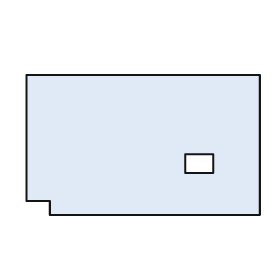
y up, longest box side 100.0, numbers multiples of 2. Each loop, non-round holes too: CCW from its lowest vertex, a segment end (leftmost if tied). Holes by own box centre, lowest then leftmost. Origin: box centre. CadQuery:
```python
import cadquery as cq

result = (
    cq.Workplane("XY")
    .moveTo(-40.0, -30.0)
    .lineTo(50.0, -30.0)
    .lineTo(50.0, 30.0)
    .lineTo(-50.0, 30.0)
    .lineTo(-50.0, -24.0)
    .lineTo(-40.0, -24.0)
    .close()
    .moveTo(18.0, -12.0)
    .lineTo(30.0, -12.0)
    .lineTo(30.0, -4.0)
    .lineTo(18.0, -4.0)
    .close()
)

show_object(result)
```